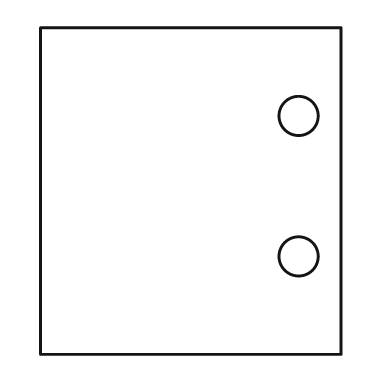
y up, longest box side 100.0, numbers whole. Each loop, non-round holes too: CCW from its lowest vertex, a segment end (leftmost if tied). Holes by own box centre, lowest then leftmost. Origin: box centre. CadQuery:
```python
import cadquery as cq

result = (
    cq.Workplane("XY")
    .moveTo(-46.0, -50.0)
    .lineTo(46.0, -50.0)
    .lineTo(46.0, 50.0)
    .lineTo(-46.0, 50.0)
    .close()
    .moveTo(33.0, -20.0)
    .circle(6.0)
    .moveTo(33.0, 23.0)
    .circle(6.0)
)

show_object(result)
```